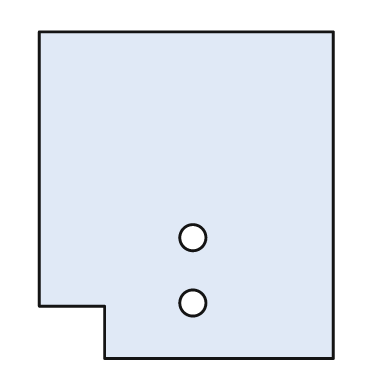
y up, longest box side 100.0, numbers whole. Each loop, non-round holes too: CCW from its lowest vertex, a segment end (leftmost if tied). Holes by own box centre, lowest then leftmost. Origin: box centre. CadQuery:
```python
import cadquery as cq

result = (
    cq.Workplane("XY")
    .moveTo(-25.0, -50.0)
    .lineTo(45.0, -50.0)
    .lineTo(45.0, 50.0)
    .lineTo(-45.0, 50.0)
    .lineTo(-45.0, -34.0)
    .lineTo(-25.0, -34.0)
    .close()
    .moveTo(2.0, -33.0)
    .circle(4.0)
    .moveTo(2.0, -13.0)
    .circle(4.0)
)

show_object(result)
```